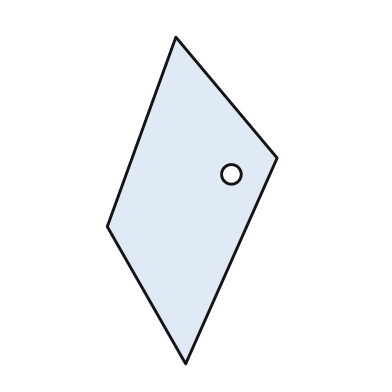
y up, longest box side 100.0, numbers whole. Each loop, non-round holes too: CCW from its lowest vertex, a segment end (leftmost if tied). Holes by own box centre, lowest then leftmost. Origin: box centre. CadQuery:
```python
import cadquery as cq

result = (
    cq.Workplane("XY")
    .moveTo(-2.0, -50.0)
    .lineTo(26.0, 13.0)
    .lineTo(-5.0, 50.0)
    .lineTo(-26.0, -8.0)
    .close()
    .moveTo(12.0, 8.0)
    .circle(3.0)
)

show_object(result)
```